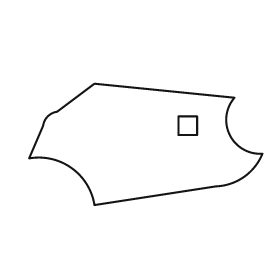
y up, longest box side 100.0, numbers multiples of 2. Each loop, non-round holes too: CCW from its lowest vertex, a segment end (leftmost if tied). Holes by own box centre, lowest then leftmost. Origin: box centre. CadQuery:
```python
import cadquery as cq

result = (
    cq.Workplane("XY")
    .moveTo(-22.0, -26.0)
    .lineTo(30.0, -18.0)
    .threePointArc((42.0, -14.0), (50.0, -4.0))
    .threePointArc((36.0, 4.0), (38.0, 20.0))
    .lineTo(-22.0, 26.0)
    .lineTo(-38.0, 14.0)
    .threePointArc((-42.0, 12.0), (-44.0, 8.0))
    .lineTo(-50.0, -6.0)
    .threePointArc((-32.0, -10.0), (-22.0, -26.0))
    .close()
    .moveTo(14.0, 4.0)
    .lineTo(22.0, 4.0)
    .lineTo(22.0, 12.0)
    .lineTo(14.0, 12.0)
    .close()
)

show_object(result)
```